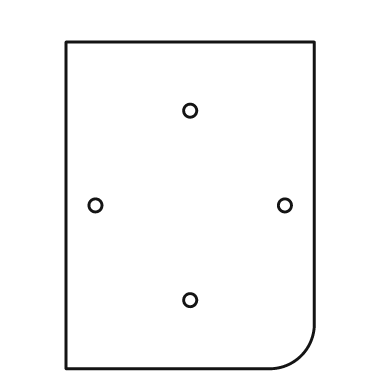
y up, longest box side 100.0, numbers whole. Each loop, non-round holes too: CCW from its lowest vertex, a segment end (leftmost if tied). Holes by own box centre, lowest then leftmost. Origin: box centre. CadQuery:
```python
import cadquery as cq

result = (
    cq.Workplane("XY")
    .moveTo(-38.0, -50.0)
    .lineTo(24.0, -50.0)
    .threePointArc((34.0, -46.0), (38.0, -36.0))
    .lineTo(38.0, 50.0)
    .lineTo(-38.0, 50.0)
    .close()
    .moveTo(0.0, -29.0)
    .circle(2.0)
    .moveTo(-29.0, 0.0)
    .circle(2.0)
    .moveTo(29.0, 0.0)
    .circle(2.0)
    .moveTo(0.0, 29.0)
    .circle(2.0)
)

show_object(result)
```